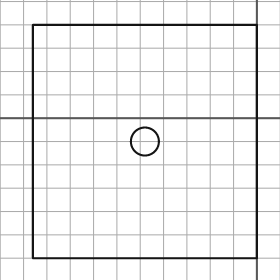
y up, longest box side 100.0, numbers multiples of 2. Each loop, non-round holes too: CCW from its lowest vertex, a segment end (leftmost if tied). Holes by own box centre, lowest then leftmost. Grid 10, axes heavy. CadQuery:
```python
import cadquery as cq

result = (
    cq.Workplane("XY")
    .moveTo(-96.0, -60.0)
    .lineTo(0.0, -60.0)
    .lineTo(0.0, 40.0)
    .lineTo(-96.0, 40.0)
    .close()
    .moveTo(-48.0, -10.0)
    .circle(6.0)
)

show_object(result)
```